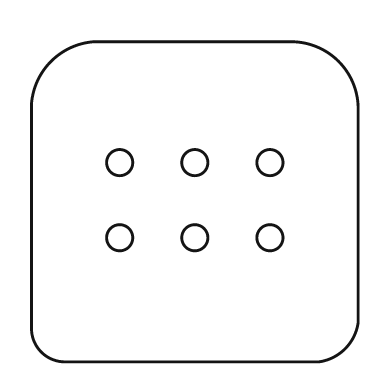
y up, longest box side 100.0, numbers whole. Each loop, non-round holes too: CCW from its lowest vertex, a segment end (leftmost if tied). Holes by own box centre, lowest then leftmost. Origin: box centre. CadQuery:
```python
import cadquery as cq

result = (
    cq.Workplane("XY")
    .moveTo(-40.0, -49.0)
    .lineTo(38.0, -49.0)
    .threePointArc((46.0, -45.0), (50.0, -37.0))
    .lineTo(50.0, 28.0)
    .threePointArc((44.0, 43.0), (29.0, 49.0))
    .lineTo(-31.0, 49.0)
    .threePointArc((-44.0, 43.0), (-50.0, 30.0))
    .lineTo(-50.0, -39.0)
    .threePointArc((-47.0, -46.0), (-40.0, -49.0))
    .close()
    .moveTo(-23.0, -11.0)
    .circle(4.0)
    .moveTo(0.0, -11.0)
    .circle(4.0)
    .moveTo(23.0, -11.0)
    .circle(4.0)
    .moveTo(-23.0, 12.0)
    .circle(4.0)
    .moveTo(0.0, 12.0)
    .circle(4.0)
    .moveTo(23.0, 12.0)
    .circle(4.0)
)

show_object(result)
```